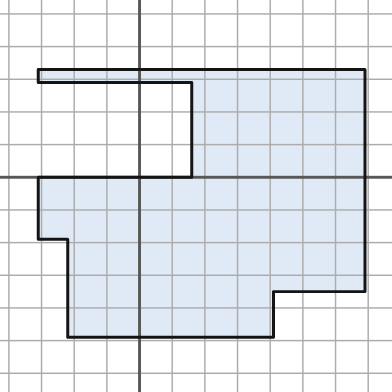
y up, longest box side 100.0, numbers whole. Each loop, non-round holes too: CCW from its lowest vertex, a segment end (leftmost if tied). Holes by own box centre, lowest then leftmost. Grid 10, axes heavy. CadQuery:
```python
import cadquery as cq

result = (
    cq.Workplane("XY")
    .moveTo(-22.0, -49.0)
    .lineTo(41.0, -49.0)
    .lineTo(41.0, -35.0)
    .lineTo(69.0, -35.0)
    .lineTo(69.0, 33.0)
    .lineTo(-31.0, 33.0)
    .lineTo(-31.0, 29.0)
    .lineTo(16.0, 29.0)
    .lineTo(16.0, 0.0)
    .lineTo(-31.0, 0.0)
    .lineTo(-31.0, -19.0)
    .lineTo(-22.0, -19.0)
    .close()
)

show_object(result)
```